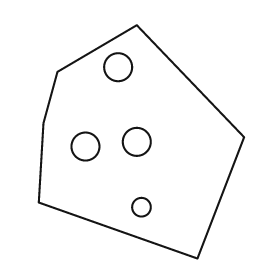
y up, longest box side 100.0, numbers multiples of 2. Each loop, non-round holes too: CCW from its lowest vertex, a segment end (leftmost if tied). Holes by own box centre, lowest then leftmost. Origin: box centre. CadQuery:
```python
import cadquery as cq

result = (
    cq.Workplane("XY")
    .moveTo(24.0, -50.0)
    .lineTo(44.0, 2.0)
    .lineTo(-2.0, 50.0)
    .lineTo(-36.0, 30.0)
    .lineTo(-42.0, 8.0)
    .lineTo(-44.0, -26.0)
    .close()
    .moveTo(0.0, -28.0)
    .circle(4.0)
    .moveTo(-24.0, -2.0)
    .circle(6.0)
    .moveTo(-2.0, 0.0)
    .circle(6.0)
    .moveTo(-10.0, 32.0)
    .circle(6.0)
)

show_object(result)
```